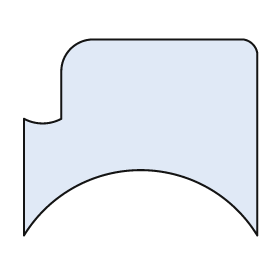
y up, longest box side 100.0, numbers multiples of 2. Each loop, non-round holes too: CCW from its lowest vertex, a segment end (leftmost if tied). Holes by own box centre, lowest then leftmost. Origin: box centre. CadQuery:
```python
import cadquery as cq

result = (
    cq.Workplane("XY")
    .moveTo(-50.0, -42.0)
    .threePointArc((0.0, -14.0), (50.0, -42.0))
    .lineTo(50.0, 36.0)
    .threePointArc((48.0, 40.0), (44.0, 42.0))
    .lineTo(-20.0, 42.0)
    .threePointArc((-30.0, 38.0), (-34.0, 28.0))
    .lineTo(-34.0, 8.0)
    .threePointArc((-42.0, 6.0), (-50.0, 8.0))
    .close()
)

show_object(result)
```